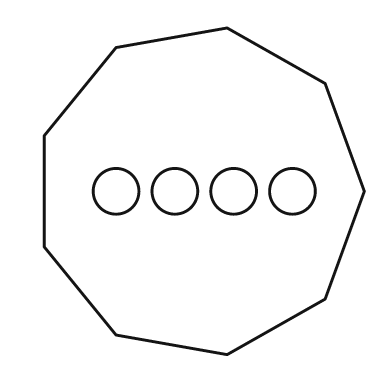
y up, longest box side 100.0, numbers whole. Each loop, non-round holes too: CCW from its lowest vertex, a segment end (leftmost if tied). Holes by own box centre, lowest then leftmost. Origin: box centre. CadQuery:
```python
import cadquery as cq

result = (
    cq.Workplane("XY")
    .moveTo(7.0, -50.0)
    .lineTo(37.0, -33.0)
    .lineTo(49.0, 0.0)
    .lineTo(37.0, 33.0)
    .lineTo(7.0, 50.0)
    .lineTo(-27.0, 44.0)
    .lineTo(-49.0, 17.0)
    .lineTo(-49.0, -17.0)
    .lineTo(-27.0, -44.0)
    .close()
    .moveTo(-27.0, 0.0)
    .circle(7.0)
    .moveTo(-9.0, 0.0)
    .circle(7.0)
    .moveTo(9.0, 0.0)
    .circle(7.0)
    .moveTo(27.0, 0.0)
    .circle(7.0)
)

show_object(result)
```